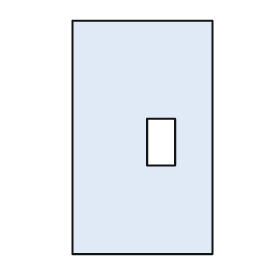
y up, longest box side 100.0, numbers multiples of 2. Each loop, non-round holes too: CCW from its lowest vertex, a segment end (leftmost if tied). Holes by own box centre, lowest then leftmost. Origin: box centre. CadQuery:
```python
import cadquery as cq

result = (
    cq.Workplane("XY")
    .moveTo(-30.0, -50.0)
    .lineTo(30.0, -50.0)
    .lineTo(30.0, 50.0)
    .lineTo(-30.0, 50.0)
    .close()
    .moveTo(2.0, -12.0)
    .lineTo(14.0, -12.0)
    .lineTo(14.0, 8.0)
    .lineTo(2.0, 8.0)
    .close()
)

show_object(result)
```